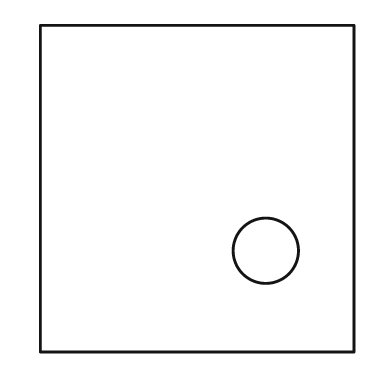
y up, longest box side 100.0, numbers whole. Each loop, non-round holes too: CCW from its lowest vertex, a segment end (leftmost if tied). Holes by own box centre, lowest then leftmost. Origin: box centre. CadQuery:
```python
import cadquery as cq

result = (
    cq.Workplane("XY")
    .moveTo(-48.0, -50.0)
    .lineTo(48.0, -50.0)
    .lineTo(48.0, 50.0)
    .lineTo(-48.0, 50.0)
    .close()
    .moveTo(21.0, -19.0)
    .circle(10.0)
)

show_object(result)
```